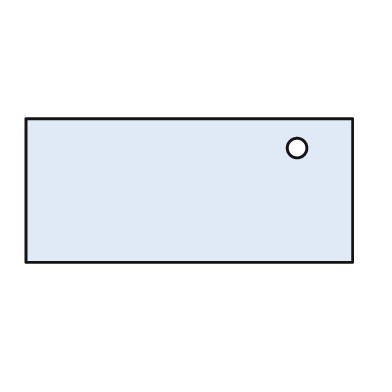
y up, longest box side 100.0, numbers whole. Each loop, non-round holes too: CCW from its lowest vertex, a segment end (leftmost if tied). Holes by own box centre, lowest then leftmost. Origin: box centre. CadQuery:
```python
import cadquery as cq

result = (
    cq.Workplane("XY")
    .moveTo(-50.0, -22.0)
    .lineTo(50.0, -22.0)
    .lineTo(50.0, 22.0)
    .lineTo(-50.0, 22.0)
    .close()
    .moveTo(33.0, 13.0)
    .circle(3.0)
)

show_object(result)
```